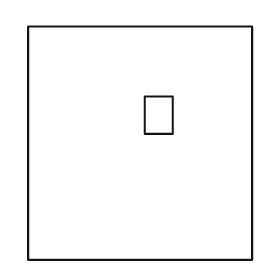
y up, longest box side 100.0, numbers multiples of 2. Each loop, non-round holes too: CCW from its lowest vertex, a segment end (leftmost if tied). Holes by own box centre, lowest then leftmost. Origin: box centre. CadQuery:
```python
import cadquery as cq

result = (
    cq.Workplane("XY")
    .moveTo(-48.0, -50.0)
    .lineTo(48.0, -50.0)
    .lineTo(48.0, 50.0)
    .lineTo(-48.0, 50.0)
    .close()
    .moveTo(2.0, 4.0)
    .lineTo(14.0, 4.0)
    .lineTo(14.0, 20.0)
    .lineTo(2.0, 20.0)
    .close()
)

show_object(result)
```